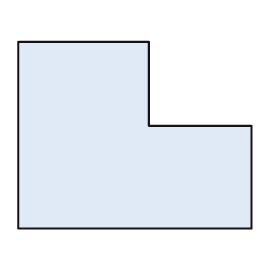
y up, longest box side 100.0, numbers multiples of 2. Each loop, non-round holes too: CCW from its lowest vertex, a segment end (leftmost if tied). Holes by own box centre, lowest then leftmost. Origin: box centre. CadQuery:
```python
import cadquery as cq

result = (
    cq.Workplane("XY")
    .moveTo(-50.0, -40.0)
    .lineTo(50.0, -40.0)
    .lineTo(50.0, 4.0)
    .lineTo(6.0, 4.0)
    .lineTo(6.0, 40.0)
    .lineTo(-50.0, 40.0)
    .close()
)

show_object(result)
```